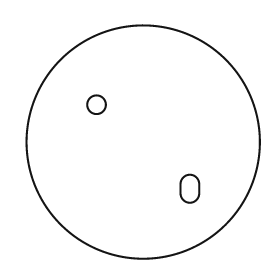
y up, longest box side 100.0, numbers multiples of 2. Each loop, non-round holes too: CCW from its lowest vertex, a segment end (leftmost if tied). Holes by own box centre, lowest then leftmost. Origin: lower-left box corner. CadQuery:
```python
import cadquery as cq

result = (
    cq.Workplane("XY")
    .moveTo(50.0, 50.0)
    .circle(50.0)
    .moveTo(66.0, 28.0)
    .threePointArc((70.0, 24.0), (74.0, 28.0))
    .lineTo(74.0, 32.0)
    .threePointArc((70.0, 36.0), (66.0, 32.0))
    .close()
    .moveTo(30.0, 66.0)
    .circle(4.0)
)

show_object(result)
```